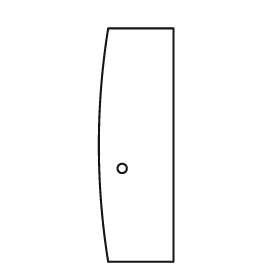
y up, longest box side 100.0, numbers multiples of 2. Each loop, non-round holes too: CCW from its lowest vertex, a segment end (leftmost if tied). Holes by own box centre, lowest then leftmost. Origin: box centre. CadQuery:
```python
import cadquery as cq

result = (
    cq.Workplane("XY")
    .moveTo(-12.0, -50.0)
    .lineTo(16.0, -50.0)
    .lineTo(16.0, 50.0)
    .lineTo(-12.0, 50.0)
    .threePointArc((-16.0, 0.0), (-12.0, -50.0))
    .close()
    .moveTo(-6.0, -10.0)
    .circle(2.0)
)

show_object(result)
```